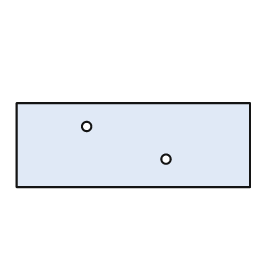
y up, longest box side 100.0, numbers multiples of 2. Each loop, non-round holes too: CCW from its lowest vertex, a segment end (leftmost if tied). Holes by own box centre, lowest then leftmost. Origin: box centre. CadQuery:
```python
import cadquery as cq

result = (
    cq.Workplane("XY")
    .moveTo(-50.0, -18.0)
    .lineTo(50.0, -18.0)
    .lineTo(50.0, 18.0)
    .lineTo(-50.0, 18.0)
    .close()
    .moveTo(14.0, -6.0)
    .circle(2.0)
    .moveTo(-20.0, 8.0)
    .circle(2.0)
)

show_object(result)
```